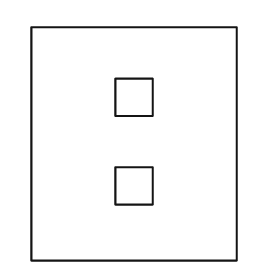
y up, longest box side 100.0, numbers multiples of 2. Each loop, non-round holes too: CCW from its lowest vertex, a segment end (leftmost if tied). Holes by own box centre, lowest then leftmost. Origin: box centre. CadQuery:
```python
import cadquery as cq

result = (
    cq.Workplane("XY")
    .moveTo(-44.0, -50.0)
    .lineTo(44.0, -50.0)
    .lineTo(44.0, 50.0)
    .lineTo(-44.0, 50.0)
    .close()
    .moveTo(-8.0, -26.0)
    .lineTo(8.0, -26.0)
    .lineTo(8.0, -10.0)
    .lineTo(-8.0, -10.0)
    .close()
    .moveTo(-8.0, 12.0)
    .lineTo(8.0, 12.0)
    .lineTo(8.0, 28.0)
    .lineTo(-8.0, 28.0)
    .close()
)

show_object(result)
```